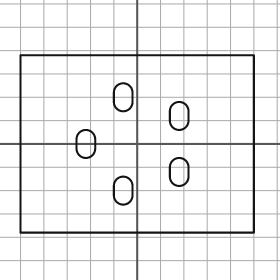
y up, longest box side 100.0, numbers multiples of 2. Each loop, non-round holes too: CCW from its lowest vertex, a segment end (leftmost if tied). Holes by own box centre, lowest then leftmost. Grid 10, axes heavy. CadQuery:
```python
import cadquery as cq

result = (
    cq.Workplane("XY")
    .moveTo(-50.0, -38.0)
    .lineTo(50.0, -38.0)
    .lineTo(50.0, 38.0)
    .lineTo(-50.0, 38.0)
    .close()
    .moveTo(-10.0, -22.0)
    .threePointArc((-6.0, -26.0), (-2.0, -22.0))
    .lineTo(-2.0, -18.0)
    .threePointArc((-6.0, -14.0), (-10.0, -18.0))
    .close()
    .moveTo(14.0, -14.0)
    .threePointArc((18.0, -18.0), (22.0, -14.0))
    .lineTo(22.0, -10.0)
    .threePointArc((18.0, -6.0), (14.0, -10.0))
    .close()
    .moveTo(-26.0, -2.0)
    .threePointArc((-22.0, -6.0), (-18.0, -2.0))
    .lineTo(-18.0, 2.0)
    .threePointArc((-22.0, 6.0), (-26.0, 2.0))
    .close()
    .moveTo(14.0, 10.0)
    .threePointArc((18.0, 6.0), (22.0, 10.0))
    .lineTo(22.0, 14.0)
    .threePointArc((18.0, 18.0), (14.0, 14.0))
    .close()
    .moveTo(-10.0, 18.0)
    .threePointArc((-6.0, 14.0), (-2.0, 18.0))
    .lineTo(-2.0, 22.0)
    .threePointArc((-6.0, 26.0), (-10.0, 22.0))
    .close()
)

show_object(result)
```